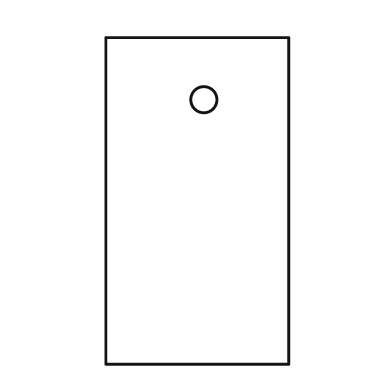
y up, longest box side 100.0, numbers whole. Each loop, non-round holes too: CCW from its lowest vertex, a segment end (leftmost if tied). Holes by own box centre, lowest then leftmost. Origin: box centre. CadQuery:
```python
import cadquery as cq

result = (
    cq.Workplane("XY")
    .moveTo(-28.0, -50.0)
    .lineTo(28.0, -50.0)
    .lineTo(28.0, 50.0)
    .lineTo(-28.0, 50.0)
    .close()
    .moveTo(2.0, 31.0)
    .circle(4.0)
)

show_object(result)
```